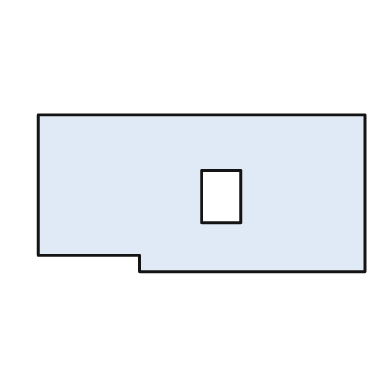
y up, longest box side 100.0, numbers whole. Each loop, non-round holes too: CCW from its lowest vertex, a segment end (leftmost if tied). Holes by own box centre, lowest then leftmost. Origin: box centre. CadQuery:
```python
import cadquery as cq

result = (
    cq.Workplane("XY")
    .moveTo(-19.0, -24.0)
    .lineTo(50.0, -24.0)
    .lineTo(50.0, 24.0)
    .lineTo(-50.0, 24.0)
    .lineTo(-50.0, -19.0)
    .lineTo(-19.0, -19.0)
    .close()
    .moveTo(0.0, -9.0)
    .lineTo(12.0, -9.0)
    .lineTo(12.0, 7.0)
    .lineTo(0.0, 7.0)
    .close()
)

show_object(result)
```